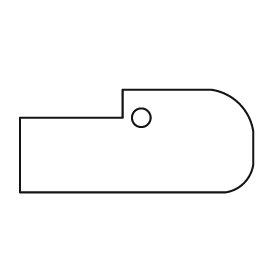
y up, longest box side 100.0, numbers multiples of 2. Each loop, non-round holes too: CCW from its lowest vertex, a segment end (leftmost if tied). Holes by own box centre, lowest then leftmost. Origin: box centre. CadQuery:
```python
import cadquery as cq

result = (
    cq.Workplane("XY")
    .moveTo(-50.0, -22.0)
    .lineTo(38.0, -22.0)
    .threePointArc((46.0, -18.0), (50.0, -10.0))
    .lineTo(50.0, 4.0)
    .threePointArc((44.0, 16.0), (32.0, 22.0))
    .lineTo(-6.0, 22.0)
    .lineTo(-6.0, 10.0)
    .lineTo(-50.0, 10.0)
    .close()
    .moveTo(2.0, 10.0)
    .circle(4.0)
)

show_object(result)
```